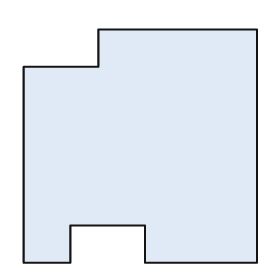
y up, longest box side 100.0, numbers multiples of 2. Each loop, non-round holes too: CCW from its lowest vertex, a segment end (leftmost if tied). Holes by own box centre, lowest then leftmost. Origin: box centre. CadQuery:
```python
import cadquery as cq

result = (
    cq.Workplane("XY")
    .moveTo(-50.0, -50.0)
    .lineTo(-30.0, -50.0)
    .lineTo(-30.0, -34.0)
    .lineTo(2.0, -34.0)
    .lineTo(2.0, -50.0)
    .lineTo(50.0, -50.0)
    .lineTo(50.0, 50.0)
    .lineTo(-18.0, 50.0)
    .lineTo(-18.0, 34.0)
    .lineTo(-50.0, 34.0)
    .close()
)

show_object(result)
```